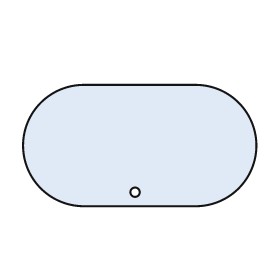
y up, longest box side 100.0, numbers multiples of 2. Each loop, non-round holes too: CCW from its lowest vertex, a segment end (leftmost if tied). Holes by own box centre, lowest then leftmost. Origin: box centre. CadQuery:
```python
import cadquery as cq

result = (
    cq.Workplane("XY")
    .moveTo(-24.0, -26.0)
    .lineTo(24.0, -26.0)
    .threePointArc((50.0, 0.0), (24.0, 26.0))
    .lineTo(-24.0, 26.0)
    .threePointArc((-50.0, 0.0), (-24.0, -26.0))
    .close()
    .moveTo(-2.0, -20.0)
    .circle(2.0)
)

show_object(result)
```